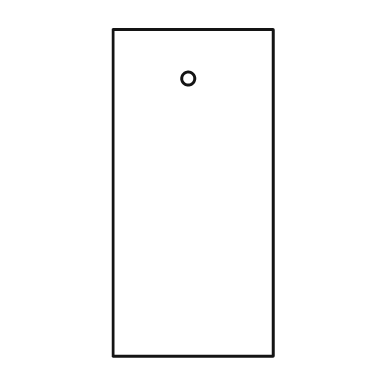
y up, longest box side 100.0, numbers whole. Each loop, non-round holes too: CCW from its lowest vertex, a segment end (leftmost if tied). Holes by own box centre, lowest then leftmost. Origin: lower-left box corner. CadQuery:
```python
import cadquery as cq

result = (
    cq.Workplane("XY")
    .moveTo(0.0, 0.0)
    .lineTo(49.0, 0.0)
    .lineTo(49.0, 100.0)
    .lineTo(0.0, 100.0)
    .close()
    .moveTo(23.0, 85.0)
    .circle(2.0)
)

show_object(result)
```